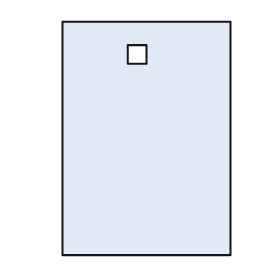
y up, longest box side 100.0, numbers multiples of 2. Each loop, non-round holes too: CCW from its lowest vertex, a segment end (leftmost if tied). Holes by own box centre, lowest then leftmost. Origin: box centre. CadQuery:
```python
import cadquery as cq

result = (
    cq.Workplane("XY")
    .moveTo(-36.0, -50.0)
    .lineTo(36.0, -50.0)
    .lineTo(36.0, 50.0)
    .lineTo(-36.0, 50.0)
    .close()
    .moveTo(-8.0, 32.0)
    .lineTo(0.0, 32.0)
    .lineTo(0.0, 40.0)
    .lineTo(-8.0, 40.0)
    .close()
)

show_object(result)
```